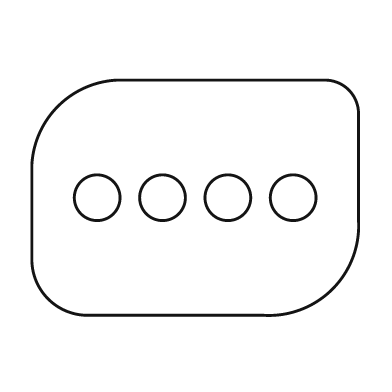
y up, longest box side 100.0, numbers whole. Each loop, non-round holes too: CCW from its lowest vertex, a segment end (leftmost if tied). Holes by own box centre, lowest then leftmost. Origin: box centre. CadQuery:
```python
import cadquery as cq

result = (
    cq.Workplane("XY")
    .moveTo(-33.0, -36.0)
    .lineTo(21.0, -36.0)
    .threePointArc((42.0, -28.0), (50.0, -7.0))
    .lineTo(50.0, 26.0)
    .threePointArc((47.0, 33.0), (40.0, 36.0))
    .lineTo(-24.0, 36.0)
    .threePointArc((-42.0, 28.0), (-50.0, 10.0))
    .lineTo(-50.0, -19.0)
    .threePointArc((-45.0, -31.0), (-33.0, -36.0))
    .close()
    .moveTo(-30.0, 0.0)
    .circle(7.0)
    .moveTo(-10.0, 0.0)
    .circle(7.0)
    .moveTo(10.0, 0.0)
    .circle(7.0)
    .moveTo(30.0, 0.0)
    .circle(7.0)
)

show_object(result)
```